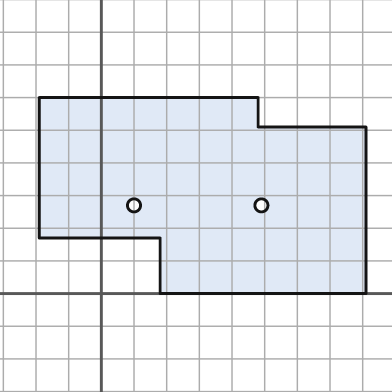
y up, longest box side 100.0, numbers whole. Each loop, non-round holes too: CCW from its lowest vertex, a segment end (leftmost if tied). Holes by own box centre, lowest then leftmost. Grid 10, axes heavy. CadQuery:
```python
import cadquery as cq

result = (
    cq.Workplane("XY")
    .moveTo(18.0, 0.0)
    .lineTo(81.0, 0.0)
    .lineTo(81.0, 51.0)
    .lineTo(48.0, 51.0)
    .lineTo(48.0, 60.0)
    .lineTo(-19.0, 60.0)
    .lineTo(-19.0, 17.0)
    .lineTo(18.0, 17.0)
    .close()
    .moveTo(10.0, 27.0)
    .circle(2.0)
    .moveTo(49.0, 27.0)
    .circle(2.0)
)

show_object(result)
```